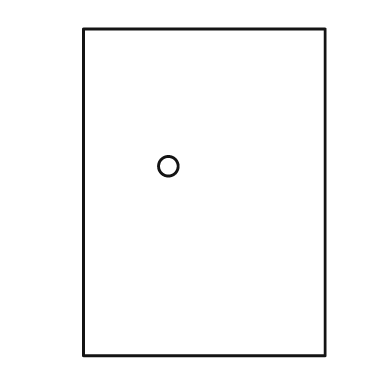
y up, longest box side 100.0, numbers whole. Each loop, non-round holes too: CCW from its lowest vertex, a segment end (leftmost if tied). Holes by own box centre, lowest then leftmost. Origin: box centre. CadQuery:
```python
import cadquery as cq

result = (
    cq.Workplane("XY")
    .moveTo(-37.0, -50.0)
    .lineTo(37.0, -50.0)
    .lineTo(37.0, 50.0)
    .lineTo(-37.0, 50.0)
    .close()
    .moveTo(-11.0, 8.0)
    .circle(3.0)
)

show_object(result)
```